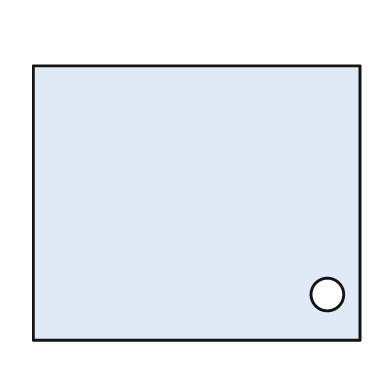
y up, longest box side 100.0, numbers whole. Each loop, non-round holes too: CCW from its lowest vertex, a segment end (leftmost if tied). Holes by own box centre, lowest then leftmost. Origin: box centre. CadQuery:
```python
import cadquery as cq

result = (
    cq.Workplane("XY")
    .moveTo(-50.0, -42.0)
    .lineTo(50.0, -42.0)
    .lineTo(50.0, 42.0)
    .lineTo(-50.0, 42.0)
    .close()
    .moveTo(40.0, -28.0)
    .circle(5.0)
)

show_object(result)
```